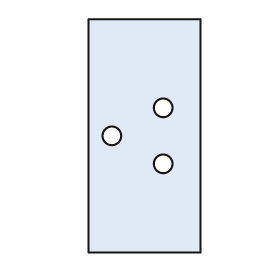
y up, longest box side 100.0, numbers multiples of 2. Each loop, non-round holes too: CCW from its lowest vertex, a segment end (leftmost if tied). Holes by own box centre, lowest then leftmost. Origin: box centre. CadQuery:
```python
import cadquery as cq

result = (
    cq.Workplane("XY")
    .moveTo(-24.0, -50.0)
    .lineTo(24.0, -50.0)
    .lineTo(24.0, 50.0)
    .lineTo(-24.0, 50.0)
    .close()
    .moveTo(8.0, -12.0)
    .circle(4.0)
    .moveTo(-14.0, 0.0)
    .circle(4.0)
    .moveTo(8.0, 12.0)
    .circle(4.0)
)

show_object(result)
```